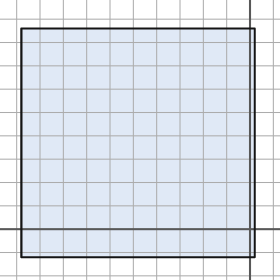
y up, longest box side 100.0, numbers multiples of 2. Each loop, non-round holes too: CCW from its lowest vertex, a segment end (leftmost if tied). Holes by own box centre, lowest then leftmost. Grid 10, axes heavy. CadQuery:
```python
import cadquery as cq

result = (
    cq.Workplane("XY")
    .moveTo(-98.0, -12.0)
    .lineTo(2.0, -12.0)
    .lineTo(2.0, 86.0)
    .lineTo(-98.0, 86.0)
    .close()
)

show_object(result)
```